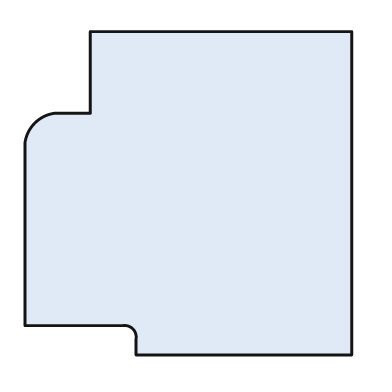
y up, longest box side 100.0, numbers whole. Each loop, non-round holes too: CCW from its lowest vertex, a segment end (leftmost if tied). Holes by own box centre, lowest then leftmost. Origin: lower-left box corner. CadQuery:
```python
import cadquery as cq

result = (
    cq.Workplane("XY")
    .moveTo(34.0, 0.0)
    .lineTo(100.0, 0.0)
    .lineTo(100.0, 99.0)
    .lineTo(20.0, 99.0)
    .lineTo(20.0, 74.0)
    .lineTo(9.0, 74.0)
    .threePointArc((3.0, 71.0), (0.0, 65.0))
    .lineTo(0.0, 9.0)
    .lineTo(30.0, 9.0)
    .threePointArc((33.0, 8.0), (34.0, 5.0))
    .close()
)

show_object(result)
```